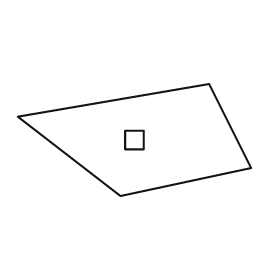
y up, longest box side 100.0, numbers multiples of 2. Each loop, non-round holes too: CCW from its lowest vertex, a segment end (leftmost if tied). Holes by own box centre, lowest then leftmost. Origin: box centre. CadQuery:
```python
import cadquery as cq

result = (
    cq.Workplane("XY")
    .moveTo(-6.0, -24.0)
    .lineTo(50.0, -12.0)
    .lineTo(32.0, 24.0)
    .lineTo(-50.0, 10.0)
    .close()
    .moveTo(-4.0, -4.0)
    .lineTo(4.0, -4.0)
    .lineTo(4.0, 4.0)
    .lineTo(-4.0, 4.0)
    .close()
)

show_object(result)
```